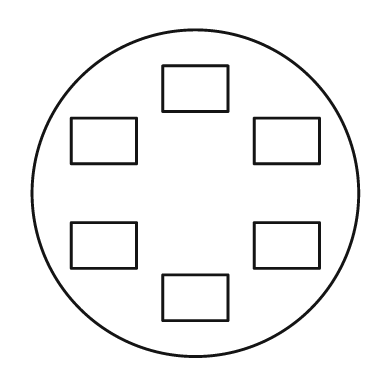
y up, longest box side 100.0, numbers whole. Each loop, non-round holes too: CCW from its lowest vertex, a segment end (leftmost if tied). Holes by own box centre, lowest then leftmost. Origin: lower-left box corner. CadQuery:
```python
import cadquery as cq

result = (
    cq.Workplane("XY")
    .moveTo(50.0, 50.0)
    .circle(50.0)
    .moveTo(40.0, 11.0)
    .lineTo(60.0, 11.0)
    .lineTo(60.0, 25.0)
    .lineTo(40.0, 25.0)
    .close()
    .moveTo(12.0, 27.0)
    .lineTo(32.0, 27.0)
    .lineTo(32.0, 41.0)
    .lineTo(12.0, 41.0)
    .close()
    .moveTo(68.0, 27.0)
    .lineTo(88.0, 27.0)
    .lineTo(88.0, 41.0)
    .lineTo(68.0, 41.0)
    .close()
    .moveTo(12.0, 59.0)
    .lineTo(32.0, 59.0)
    .lineTo(32.0, 73.0)
    .lineTo(12.0, 73.0)
    .close()
    .moveTo(68.0, 59.0)
    .lineTo(88.0, 59.0)
    .lineTo(88.0, 73.0)
    .lineTo(68.0, 73.0)
    .close()
    .moveTo(40.0, 75.0)
    .lineTo(60.0, 75.0)
    .lineTo(60.0, 89.0)
    .lineTo(40.0, 89.0)
    .close()
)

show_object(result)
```